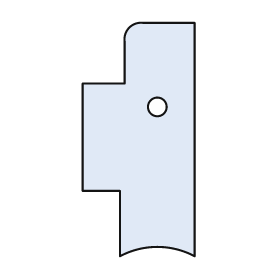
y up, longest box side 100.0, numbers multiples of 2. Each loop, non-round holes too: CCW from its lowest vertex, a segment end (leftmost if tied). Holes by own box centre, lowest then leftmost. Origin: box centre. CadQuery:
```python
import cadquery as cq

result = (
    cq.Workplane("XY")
    .moveTo(-8.0, -50.0)
    .threePointArc((8.0, -46.0), (24.0, -50.0))
    .lineTo(24.0, 50.0)
    .lineTo(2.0, 50.0)
    .threePointArc((-4.0, 48.0), (-6.0, 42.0))
    .lineTo(-6.0, 24.0)
    .lineTo(-24.0, 24.0)
    .lineTo(-24.0, -22.0)
    .lineTo(-8.0, -22.0)
    .close()
    .moveTo(8.0, 14.0)
    .circle(4.0)
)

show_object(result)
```